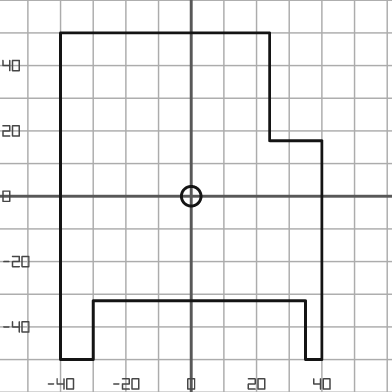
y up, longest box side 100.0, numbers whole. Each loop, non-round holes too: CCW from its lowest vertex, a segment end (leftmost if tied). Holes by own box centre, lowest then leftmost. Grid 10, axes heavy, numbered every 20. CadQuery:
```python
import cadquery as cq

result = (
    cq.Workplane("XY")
    .moveTo(-40.0, -50.0)
    .lineTo(-30.0, -50.0)
    .lineTo(-30.0, -32.0)
    .lineTo(35.0, -32.0)
    .lineTo(35.0, -50.0)
    .lineTo(40.0, -50.0)
    .lineTo(40.0, 17.0)
    .lineTo(24.0, 17.0)
    .lineTo(24.0, 50.0)
    .lineTo(-40.0, 50.0)
    .close()
    .moveTo(0.0, 0.0)
    .circle(3.0)
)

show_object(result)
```